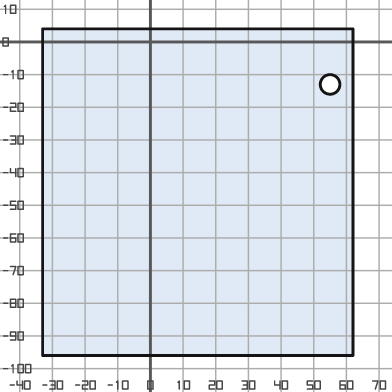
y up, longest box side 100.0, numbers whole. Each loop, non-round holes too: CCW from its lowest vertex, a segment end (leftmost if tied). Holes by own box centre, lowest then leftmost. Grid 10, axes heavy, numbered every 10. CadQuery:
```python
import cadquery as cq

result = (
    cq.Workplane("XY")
    .moveTo(-33.0, -96.0)
    .lineTo(62.0, -96.0)
    .lineTo(62.0, 4.0)
    .lineTo(-33.0, 4.0)
    .close()
    .moveTo(55.0, -13.0)
    .circle(3.0)
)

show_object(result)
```